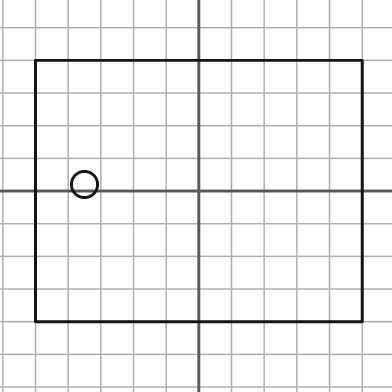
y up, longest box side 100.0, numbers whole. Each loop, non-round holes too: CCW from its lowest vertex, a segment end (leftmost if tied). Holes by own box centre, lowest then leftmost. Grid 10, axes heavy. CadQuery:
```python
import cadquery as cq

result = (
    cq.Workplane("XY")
    .moveTo(-50.0, -40.0)
    .lineTo(50.0, -40.0)
    .lineTo(50.0, 40.0)
    .lineTo(-50.0, 40.0)
    .close()
    .moveTo(-35.0, 2.0)
    .circle(4.0)
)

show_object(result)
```